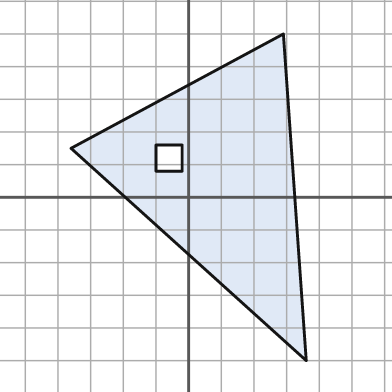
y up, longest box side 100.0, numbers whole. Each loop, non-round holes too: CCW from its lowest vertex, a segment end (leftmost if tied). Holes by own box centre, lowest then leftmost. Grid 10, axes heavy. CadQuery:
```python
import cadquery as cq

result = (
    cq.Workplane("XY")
    .moveTo(36.0, -50.0)
    .lineTo(29.0, 50.0)
    .lineTo(-36.0, 15.0)
    .close()
    .moveTo(-10.0, 8.0)
    .lineTo(-2.0, 8.0)
    .lineTo(-2.0, 16.0)
    .lineTo(-10.0, 16.0)
    .close()
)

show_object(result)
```